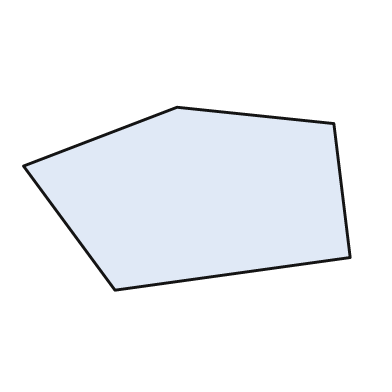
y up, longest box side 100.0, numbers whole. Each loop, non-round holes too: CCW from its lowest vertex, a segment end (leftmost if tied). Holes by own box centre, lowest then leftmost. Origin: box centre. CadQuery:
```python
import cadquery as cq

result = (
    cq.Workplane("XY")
    .moveTo(-22.0, -28.0)
    .lineTo(50.0, -18.0)
    .lineTo(45.0, 23.0)
    .lineTo(-3.0, 28.0)
    .lineTo(-50.0, 10.0)
    .close()
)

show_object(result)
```